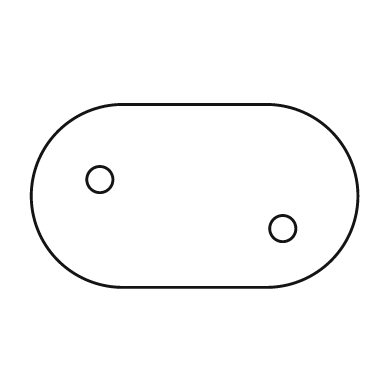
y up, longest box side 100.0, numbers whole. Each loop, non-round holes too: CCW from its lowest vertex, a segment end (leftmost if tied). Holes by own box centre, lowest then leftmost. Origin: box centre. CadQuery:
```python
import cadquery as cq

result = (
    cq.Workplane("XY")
    .moveTo(-22.0, -28.0)
    .lineTo(22.0, -28.0)
    .threePointArc((50.0, 0.0), (22.0, 28.0))
    .lineTo(-22.0, 28.0)
    .threePointArc((-50.0, 0.0), (-22.0, -28.0))
    .close()
    .moveTo(27.0, -10.0)
    .circle(4.0)
    .moveTo(-29.0, 5.0)
    .circle(4.0)
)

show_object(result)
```